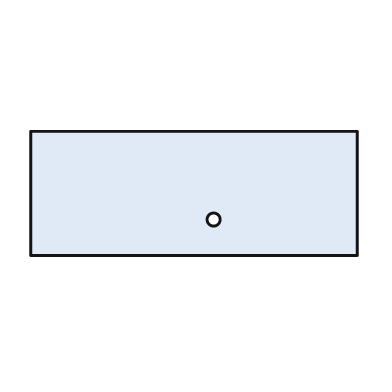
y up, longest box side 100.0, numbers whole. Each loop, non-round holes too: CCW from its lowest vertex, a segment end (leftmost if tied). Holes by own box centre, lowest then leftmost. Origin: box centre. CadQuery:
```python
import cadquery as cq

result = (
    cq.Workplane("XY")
    .moveTo(-50.0, -19.0)
    .lineTo(50.0, -19.0)
    .lineTo(50.0, 19.0)
    .lineTo(-50.0, 19.0)
    .close()
    .moveTo(6.0, -8.0)
    .circle(2.0)
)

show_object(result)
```